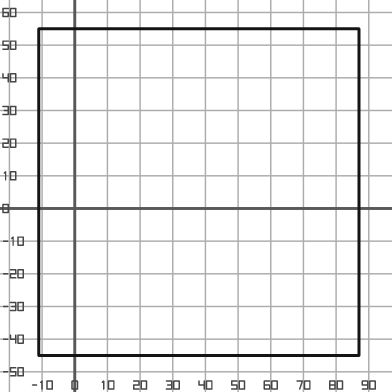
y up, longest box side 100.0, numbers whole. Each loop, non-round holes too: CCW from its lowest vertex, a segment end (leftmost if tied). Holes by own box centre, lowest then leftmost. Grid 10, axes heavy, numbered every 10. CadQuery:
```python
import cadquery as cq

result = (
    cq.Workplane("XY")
    .moveTo(-11.0, -45.0)
    .lineTo(87.0, -45.0)
    .lineTo(87.0, 55.0)
    .lineTo(-11.0, 55.0)
    .close()
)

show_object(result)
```